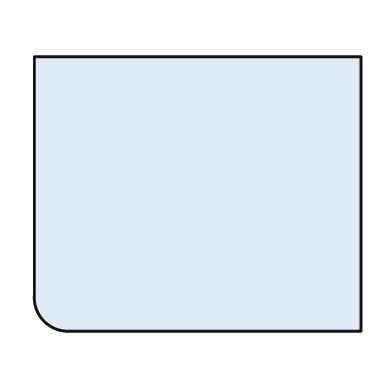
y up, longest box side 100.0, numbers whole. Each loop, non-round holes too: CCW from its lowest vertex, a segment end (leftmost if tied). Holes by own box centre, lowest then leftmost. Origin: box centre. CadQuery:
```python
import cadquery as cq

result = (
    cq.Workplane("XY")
    .moveTo(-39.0, -42.0)
    .lineTo(50.0, -42.0)
    .lineTo(50.0, 42.0)
    .lineTo(-50.0, 42.0)
    .lineTo(-50.0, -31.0)
    .threePointArc((-47.0, -39.0), (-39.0, -42.0))
    .close()
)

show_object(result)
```